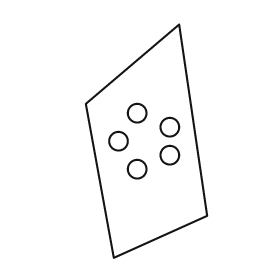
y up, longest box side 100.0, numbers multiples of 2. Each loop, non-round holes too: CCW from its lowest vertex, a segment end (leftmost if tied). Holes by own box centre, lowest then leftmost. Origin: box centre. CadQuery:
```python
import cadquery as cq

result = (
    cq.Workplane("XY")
    .moveTo(-14.0, -50.0)
    .lineTo(26.0, -32.0)
    .lineTo(14.0, 50.0)
    .lineTo(-26.0, 16.0)
    .close()
    .moveTo(-4.0, -12.0)
    .circle(4.0)
    .moveTo(10.0, -6.0)
    .circle(4.0)
    .moveTo(-12.0, 0.0)
    .circle(4.0)
    .moveTo(10.0, 6.0)
    .circle(4.0)
    .moveTo(-4.0, 12.0)
    .circle(4.0)
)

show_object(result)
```